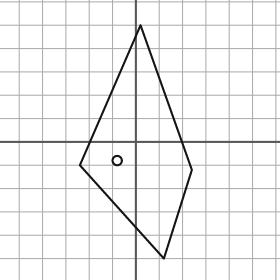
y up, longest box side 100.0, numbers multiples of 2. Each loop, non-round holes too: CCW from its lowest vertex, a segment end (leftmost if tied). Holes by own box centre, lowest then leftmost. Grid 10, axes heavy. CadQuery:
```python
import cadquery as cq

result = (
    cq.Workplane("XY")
    .moveTo(12.0, -50.0)
    .lineTo(24.0, -12.0)
    .lineTo(2.0, 50.0)
    .lineTo(-24.0, -10.0)
    .close()
    .moveTo(-8.0, -8.0)
    .circle(2.0)
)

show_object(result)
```